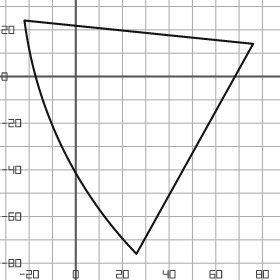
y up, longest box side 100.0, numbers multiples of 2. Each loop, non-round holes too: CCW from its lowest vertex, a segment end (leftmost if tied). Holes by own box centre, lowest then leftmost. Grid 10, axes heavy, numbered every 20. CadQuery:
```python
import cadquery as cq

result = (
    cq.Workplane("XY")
    .moveTo(26.0, -76.0)
    .lineTo(76.0, 14.0)
    .lineTo(-22.0, 24.0)
    .threePointArc((-6.0, -30.0), (26.0, -76.0))
    .close()
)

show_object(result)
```